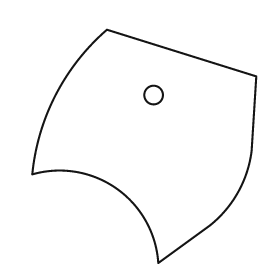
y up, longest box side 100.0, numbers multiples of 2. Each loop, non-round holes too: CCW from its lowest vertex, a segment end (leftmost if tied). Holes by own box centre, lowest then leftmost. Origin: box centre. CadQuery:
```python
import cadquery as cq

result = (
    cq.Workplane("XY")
    .moveTo(6.0, -50.0)
    .lineTo(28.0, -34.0)
    .threePointArc((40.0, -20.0), (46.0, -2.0))
    .lineTo(48.0, 30.0)
    .lineTo(-16.0, 50.0)
    .threePointArc((-38.0, 22.0), (-48.0, -12.0))
    .threePointArc((-12.0, -18.0), (6.0, -50.0))
    .close()
    .moveTo(4.0, 22.0)
    .circle(4.0)
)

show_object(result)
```